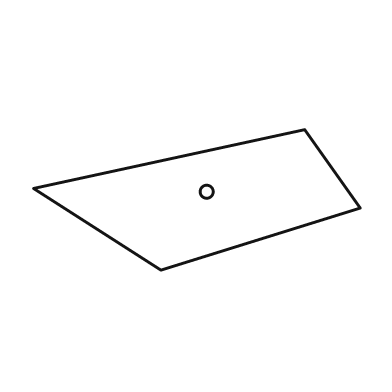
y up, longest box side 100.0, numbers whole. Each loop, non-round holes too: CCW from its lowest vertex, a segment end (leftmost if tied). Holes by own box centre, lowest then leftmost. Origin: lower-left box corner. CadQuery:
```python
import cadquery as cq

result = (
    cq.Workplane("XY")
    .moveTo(39.0, 0.0)
    .lineTo(100.0, 19.0)
    .lineTo(83.0, 43.0)
    .lineTo(0.0, 25.0)
    .close()
    .moveTo(53.0, 24.0)
    .circle(2.0)
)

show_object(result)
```